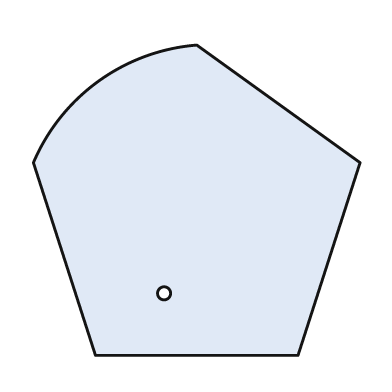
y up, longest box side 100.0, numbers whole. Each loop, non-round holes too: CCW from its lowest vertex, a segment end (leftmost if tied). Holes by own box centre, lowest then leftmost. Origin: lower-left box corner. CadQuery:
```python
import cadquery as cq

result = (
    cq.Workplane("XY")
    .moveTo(19.0, 0.0)
    .lineTo(81.0, 0.0)
    .lineTo(100.0, 59.0)
    .lineTo(50.0, 95.0)
    .threePointArc((20.0, 84.0), (0.0, 59.0))
    .close()
    .moveTo(40.0, 19.0)
    .circle(2.0)
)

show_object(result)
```